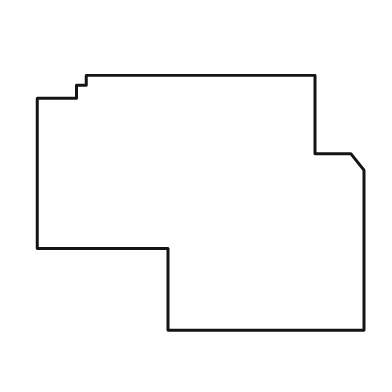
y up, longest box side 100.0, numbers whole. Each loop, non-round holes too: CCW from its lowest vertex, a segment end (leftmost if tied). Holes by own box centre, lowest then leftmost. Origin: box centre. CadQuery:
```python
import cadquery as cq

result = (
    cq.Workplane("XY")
    .moveTo(-10.0, -39.0)
    .lineTo(50.0, -39.0)
    .lineTo(50.0, 10.0)
    .lineTo(46.0, 15.0)
    .lineTo(35.0, 15.0)
    .lineTo(35.0, 39.0)
    .lineTo(-35.0, 39.0)
    .lineTo(-35.0, 36.0)
    .lineTo(-38.0, 36.0)
    .lineTo(-38.0, 32.0)
    .lineTo(-50.0, 32.0)
    .lineTo(-50.0, -14.0)
    .lineTo(-10.0, -14.0)
    .close()
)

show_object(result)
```